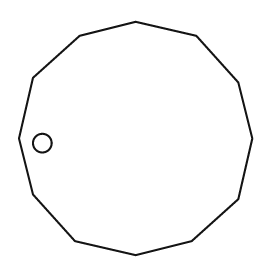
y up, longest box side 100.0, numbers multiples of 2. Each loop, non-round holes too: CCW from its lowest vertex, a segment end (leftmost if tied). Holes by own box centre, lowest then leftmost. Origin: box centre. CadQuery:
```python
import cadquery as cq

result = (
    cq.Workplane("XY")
    .moveTo(0.0, -50.0)
    .lineTo(24.0, -44.0)
    .lineTo(44.0, -26.0)
    .lineTo(50.0, 0.0)
    .lineTo(44.0, 24.0)
    .lineTo(26.0, 44.0)
    .lineTo(0.0, 50.0)
    .lineTo(-24.0, 44.0)
    .lineTo(-44.0, 26.0)
    .lineTo(-50.0, 0.0)
    .lineTo(-44.0, -24.0)
    .lineTo(-26.0, -44.0)
    .close()
    .moveTo(-40.0, -2.0)
    .circle(4.0)
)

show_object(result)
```